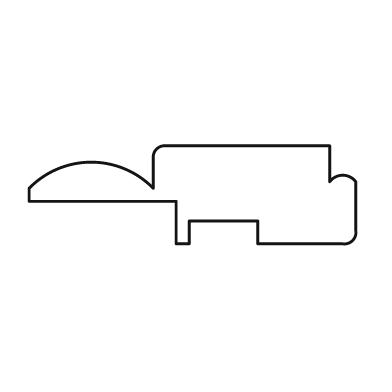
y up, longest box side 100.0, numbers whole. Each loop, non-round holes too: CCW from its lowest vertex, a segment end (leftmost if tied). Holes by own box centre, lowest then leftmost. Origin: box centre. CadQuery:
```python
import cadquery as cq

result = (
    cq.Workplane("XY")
    .moveTo(-5.0, -15.0)
    .lineTo(-1.0, -15.0)
    .lineTo(-1.0, -8.0)
    .lineTo(20.0, -8.0)
    .lineTo(20.0, -15.0)
    .lineTo(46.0, -15.0)
    .threePointArc((49.0, -14.0), (50.0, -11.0))
    .lineTo(50.0, 4.0)
    .threePointArc((46.0, 6.0), (42.0, 4.0))
    .lineTo(42.0, 15.0)
    .lineTo(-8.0, 15.0)
    .threePointArc((-11.0, 14.0), (-12.0, 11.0))
    .lineTo(-12.0, 2.0)
    .threePointArc((-31.0, 10.0), (-50.0, 2.0))
    .lineTo(-50.0, -2.0)
    .lineTo(-5.0, -2.0)
    .close()
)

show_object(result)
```